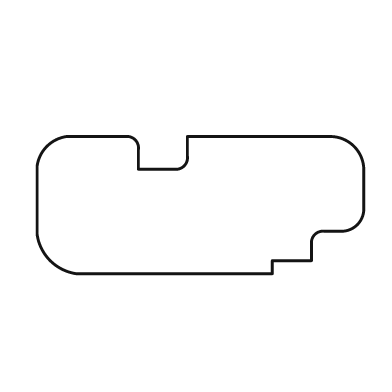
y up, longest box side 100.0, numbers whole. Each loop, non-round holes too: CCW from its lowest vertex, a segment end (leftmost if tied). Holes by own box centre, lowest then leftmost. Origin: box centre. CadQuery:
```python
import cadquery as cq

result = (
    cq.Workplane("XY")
    .moveTo(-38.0, -21.0)
    .lineTo(22.0, -21.0)
    .lineTo(22.0, -17.0)
    .lineTo(34.0, -17.0)
    .lineTo(34.0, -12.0)
    .threePointArc((35.0, -9.0), (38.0, -8.0))
    .lineTo(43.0, -8.0)
    .threePointArc((48.0, -6.0), (50.0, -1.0))
    .lineTo(50.0, 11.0)
    .threePointArc((47.0, 18.0), (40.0, 21.0))
    .lineTo(-4.0, 21.0)
    .lineTo(-4.0, 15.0)
    .threePointArc((-5.0, 12.0), (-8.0, 11.0))
    .lineTo(-19.0, 11.0)
    .lineTo(-19.0, 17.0)
    .threePointArc((-20.0, 20.0), (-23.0, 21.0))
    .lineTo(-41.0, 21.0)
    .threePointArc((-47.0, 18.0), (-50.0, 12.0))
    .lineTo(-50.0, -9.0)
    .threePointArc((-46.0, -17.0), (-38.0, -21.0))
    .close()
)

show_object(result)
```